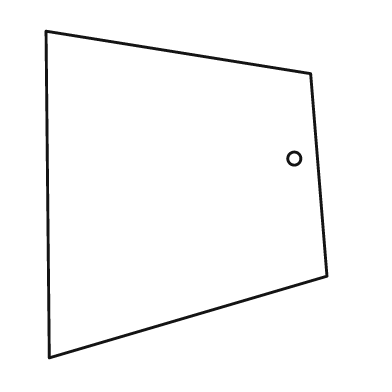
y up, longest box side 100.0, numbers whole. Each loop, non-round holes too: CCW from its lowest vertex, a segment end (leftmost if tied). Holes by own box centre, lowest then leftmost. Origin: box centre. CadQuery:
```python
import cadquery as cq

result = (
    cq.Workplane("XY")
    .moveTo(-42.0, -50.0)
    .lineTo(43.0, -25.0)
    .lineTo(38.0, 37.0)
    .lineTo(-43.0, 50.0)
    .close()
    .moveTo(33.0, 11.0)
    .circle(2.0)
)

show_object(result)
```